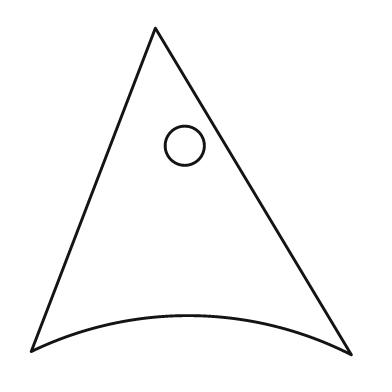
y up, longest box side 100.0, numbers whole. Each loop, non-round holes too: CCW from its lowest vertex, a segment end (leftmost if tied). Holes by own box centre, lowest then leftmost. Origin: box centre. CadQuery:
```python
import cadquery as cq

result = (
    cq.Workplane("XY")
    .moveTo(49.0, -50.0)
    .lineTo(-11.0, 50.0)
    .lineTo(-49.0, -49.0)
    .threePointArc((0.0, -38.0), (49.0, -50.0))
    .close()
    .moveTo(-2.0, 14.0)
    .circle(6.0)
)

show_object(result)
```